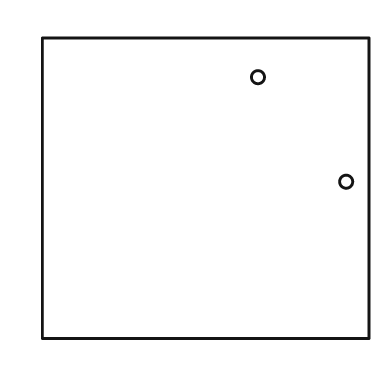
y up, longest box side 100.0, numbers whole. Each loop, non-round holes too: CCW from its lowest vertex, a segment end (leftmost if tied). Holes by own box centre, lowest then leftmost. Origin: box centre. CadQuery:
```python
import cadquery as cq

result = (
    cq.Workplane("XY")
    .moveTo(-50.0, -46.0)
    .lineTo(50.0, -46.0)
    .lineTo(50.0, 46.0)
    .lineTo(-50.0, 46.0)
    .close()
    .moveTo(43.0, 2.0)
    .circle(2.0)
    .moveTo(16.0, 34.0)
    .circle(2.0)
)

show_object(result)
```